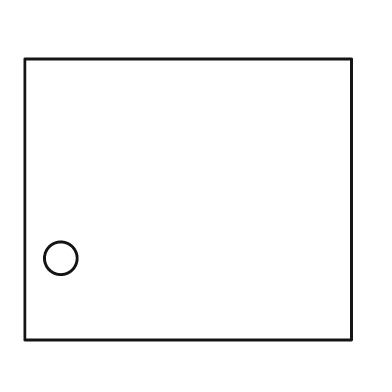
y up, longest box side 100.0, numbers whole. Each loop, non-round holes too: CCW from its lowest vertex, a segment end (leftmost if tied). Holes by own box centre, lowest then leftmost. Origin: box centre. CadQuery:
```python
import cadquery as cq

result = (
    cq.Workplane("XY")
    .moveTo(-50.0, -43.0)
    .lineTo(50.0, -43.0)
    .lineTo(50.0, 43.0)
    .lineTo(-50.0, 43.0)
    .close()
    .moveTo(-39.0, -18.0)
    .circle(5.0)
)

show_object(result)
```